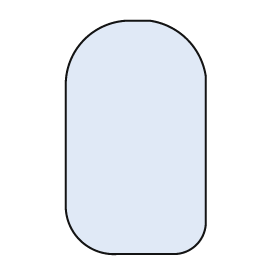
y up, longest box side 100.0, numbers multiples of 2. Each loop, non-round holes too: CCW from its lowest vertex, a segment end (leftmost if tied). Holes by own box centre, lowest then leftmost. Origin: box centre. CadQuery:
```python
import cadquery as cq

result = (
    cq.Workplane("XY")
    .moveTo(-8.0, -50.0)
    .lineTo(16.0, -50.0)
    .threePointArc((26.0, -46.0), (30.0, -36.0))
    .lineTo(30.0, 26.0)
    .threePointArc((22.0, 42.0), (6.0, 50.0))
    .lineTo(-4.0, 50.0)
    .threePointArc((-22.0, 42.0), (-30.0, 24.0))
    .lineTo(-30.0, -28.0)
    .threePointArc((-24.0, -44.0), (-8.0, -50.0))
    .close()
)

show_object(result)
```